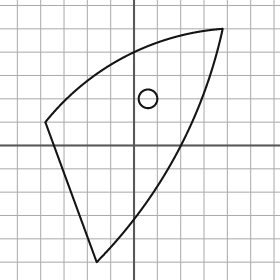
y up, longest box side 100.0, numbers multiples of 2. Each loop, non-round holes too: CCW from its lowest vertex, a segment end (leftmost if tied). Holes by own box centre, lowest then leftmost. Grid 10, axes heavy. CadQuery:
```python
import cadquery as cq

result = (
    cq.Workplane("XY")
    .moveTo(-16.0, -50.0)
    .threePointArc((18.0, -4.0), (38.0, 50.0))
    .threePointArc((-4.0, 38.0), (-38.0, 10.0))
    .close()
    .moveTo(6.0, 20.0)
    .circle(4.0)
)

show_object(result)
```